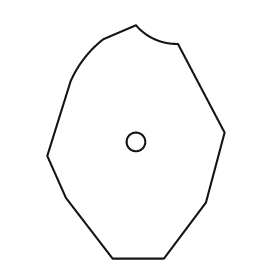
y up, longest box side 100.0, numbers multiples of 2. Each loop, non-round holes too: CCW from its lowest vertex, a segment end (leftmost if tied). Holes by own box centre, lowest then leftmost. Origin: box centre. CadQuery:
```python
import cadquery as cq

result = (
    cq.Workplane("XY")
    .moveTo(-10.0, -50.0)
    .lineTo(12.0, -50.0)
    .lineTo(30.0, -26.0)
    .lineTo(38.0, 4.0)
    .lineTo(18.0, 42.0)
    .threePointArc((8.0, 44.0), (0.0, 50.0))
    .lineTo(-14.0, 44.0)
    .threePointArc((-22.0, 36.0), (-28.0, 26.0))
    .lineTo(-38.0, -6.0)
    .lineTo(-30.0, -24.0)
    .close()
    .moveTo(0.0, 0.0)
    .circle(4.0)
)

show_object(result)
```